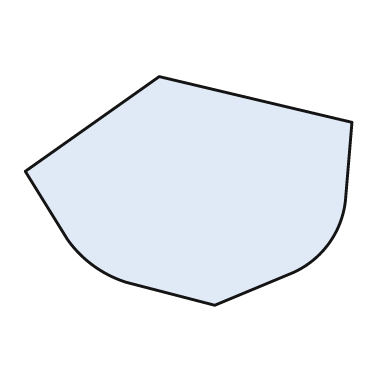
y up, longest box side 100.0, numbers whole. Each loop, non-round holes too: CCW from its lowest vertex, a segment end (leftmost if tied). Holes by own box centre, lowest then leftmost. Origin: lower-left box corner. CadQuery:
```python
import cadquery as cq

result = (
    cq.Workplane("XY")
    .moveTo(58.0, 0.0)
    .lineTo(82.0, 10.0)
    .threePointArc((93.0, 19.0), (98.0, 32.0))
    .lineTo(100.0, 56.0)
    .lineTo(41.0, 70.0)
    .lineTo(0.0, 41.0)
    .lineTo(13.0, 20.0)
    .threePointArc((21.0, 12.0), (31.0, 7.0))
    .close()
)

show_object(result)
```